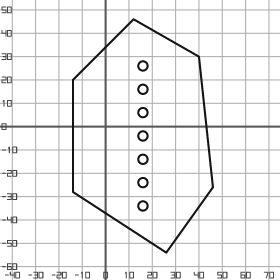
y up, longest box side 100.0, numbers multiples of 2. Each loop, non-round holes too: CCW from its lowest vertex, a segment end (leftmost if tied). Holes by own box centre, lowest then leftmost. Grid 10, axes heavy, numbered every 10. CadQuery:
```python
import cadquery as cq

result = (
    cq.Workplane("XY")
    .moveTo(26.0, -54.0)
    .lineTo(46.0, -26.0)
    .lineTo(40.0, 30.0)
    .lineTo(12.0, 46.0)
    .lineTo(-14.0, 20.0)
    .lineTo(-14.0, -28.0)
    .close()
    .moveTo(16.0, -34.0)
    .circle(2.0)
    .moveTo(16.0, -24.0)
    .circle(2.0)
    .moveTo(16.0, -14.0)
    .circle(2.0)
    .moveTo(16.0, -4.0)
    .circle(2.0)
    .moveTo(16.0, 6.0)
    .circle(2.0)
    .moveTo(16.0, 16.0)
    .circle(2.0)
    .moveTo(16.0, 26.0)
    .circle(2.0)
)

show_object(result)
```